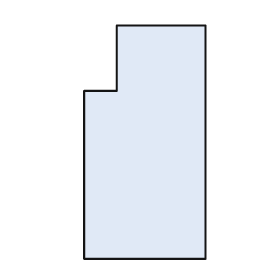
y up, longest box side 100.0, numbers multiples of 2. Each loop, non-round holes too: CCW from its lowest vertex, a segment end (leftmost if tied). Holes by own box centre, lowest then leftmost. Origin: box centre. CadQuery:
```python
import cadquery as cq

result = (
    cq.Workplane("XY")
    .moveTo(-26.0, -50.0)
    .lineTo(26.0, -50.0)
    .lineTo(26.0, 50.0)
    .lineTo(-12.0, 50.0)
    .lineTo(-12.0, 22.0)
    .lineTo(-26.0, 22.0)
    .close()
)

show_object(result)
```